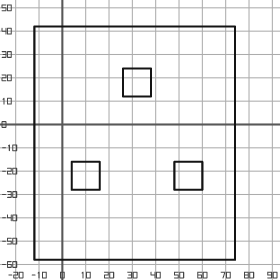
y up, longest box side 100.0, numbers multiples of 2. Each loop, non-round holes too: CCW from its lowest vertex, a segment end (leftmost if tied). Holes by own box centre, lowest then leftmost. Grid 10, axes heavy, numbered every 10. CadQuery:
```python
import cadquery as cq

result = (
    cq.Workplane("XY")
    .moveTo(-12.0, -58.0)
    .lineTo(74.0, -58.0)
    .lineTo(74.0, 42.0)
    .lineTo(-12.0, 42.0)
    .close()
    .moveTo(4.0, -28.0)
    .lineTo(16.0, -28.0)
    .lineTo(16.0, -16.0)
    .lineTo(4.0, -16.0)
    .close()
    .moveTo(48.0, -28.0)
    .lineTo(60.0, -28.0)
    .lineTo(60.0, -16.0)
    .lineTo(48.0, -16.0)
    .close()
    .moveTo(26.0, 12.0)
    .lineTo(38.0, 12.0)
    .lineTo(38.0, 24.0)
    .lineTo(26.0, 24.0)
    .close()
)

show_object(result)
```